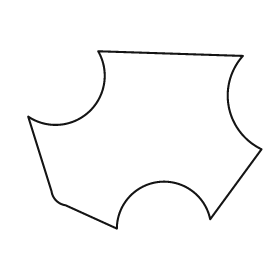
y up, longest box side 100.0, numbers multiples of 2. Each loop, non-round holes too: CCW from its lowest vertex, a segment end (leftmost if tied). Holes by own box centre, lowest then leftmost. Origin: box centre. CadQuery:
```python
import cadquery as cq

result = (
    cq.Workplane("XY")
    .moveTo(-12.0, -38.0)
    .threePointArc((6.0, -18.0), (28.0, -34.0))
    .lineTo(50.0, -4.0)
    .threePointArc((36.0, 14.0), (42.0, 36.0))
    .lineTo(-20.0, 38.0)
    .threePointArc((-24.0, 12.0), (-50.0, 10.0))
    .lineTo(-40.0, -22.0)
    .threePointArc((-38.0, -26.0), (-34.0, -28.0))
    .close()
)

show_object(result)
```